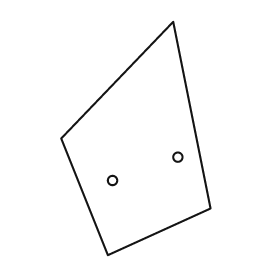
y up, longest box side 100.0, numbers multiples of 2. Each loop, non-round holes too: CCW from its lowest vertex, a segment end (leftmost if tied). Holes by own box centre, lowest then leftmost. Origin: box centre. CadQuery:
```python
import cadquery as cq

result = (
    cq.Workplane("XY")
    .moveTo(-12.0, -50.0)
    .lineTo(32.0, -30.0)
    .lineTo(16.0, 50.0)
    .lineTo(-32.0, 0.0)
    .close()
    .moveTo(-10.0, -18.0)
    .circle(2.0)
    .moveTo(18.0, -8.0)
    .circle(2.0)
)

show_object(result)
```